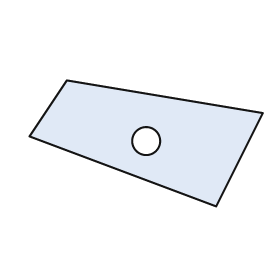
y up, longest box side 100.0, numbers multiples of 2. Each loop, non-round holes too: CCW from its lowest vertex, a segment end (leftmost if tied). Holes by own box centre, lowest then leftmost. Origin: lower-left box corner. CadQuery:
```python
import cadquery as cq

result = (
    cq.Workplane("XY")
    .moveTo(80.0, 0.0)
    .lineTo(100.0, 40.0)
    .lineTo(16.0, 54.0)
    .lineTo(0.0, 30.0)
    .close()
    .moveTo(50.0, 28.0)
    .circle(6.0)
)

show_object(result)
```